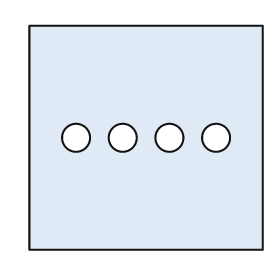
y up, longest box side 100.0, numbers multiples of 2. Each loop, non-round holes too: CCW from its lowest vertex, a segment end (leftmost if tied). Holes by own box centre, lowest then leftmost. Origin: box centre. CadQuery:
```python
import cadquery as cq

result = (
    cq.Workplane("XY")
    .moveTo(-50.0, -48.0)
    .lineTo(50.0, -48.0)
    .lineTo(50.0, 48.0)
    .lineTo(-50.0, 48.0)
    .close()
    .moveTo(-30.0, 0.0)
    .circle(6.0)
    .moveTo(-10.0, 0.0)
    .circle(6.0)
    .moveTo(10.0, 0.0)
    .circle(6.0)
    .moveTo(30.0, 0.0)
    .circle(6.0)
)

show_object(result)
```